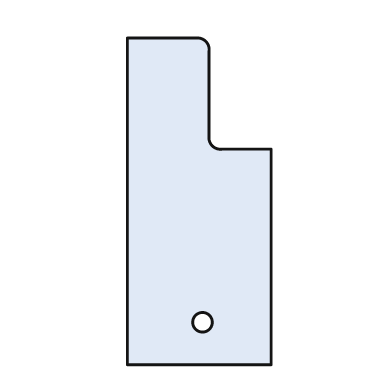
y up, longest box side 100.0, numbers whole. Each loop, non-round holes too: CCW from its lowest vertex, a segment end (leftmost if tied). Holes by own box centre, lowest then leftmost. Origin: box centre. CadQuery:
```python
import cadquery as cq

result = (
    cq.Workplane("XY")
    .moveTo(-22.0, -50.0)
    .lineTo(22.0, -50.0)
    .lineTo(22.0, 16.0)
    .lineTo(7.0, 16.0)
    .threePointArc((4.0, 17.0), (3.0, 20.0))
    .lineTo(3.0, 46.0)
    .threePointArc((2.0, 49.0), (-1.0, 50.0))
    .lineTo(-22.0, 50.0)
    .close()
    .moveTo(1.0, -37.0)
    .circle(3.0)
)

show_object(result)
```